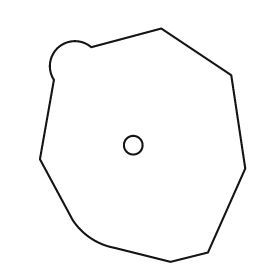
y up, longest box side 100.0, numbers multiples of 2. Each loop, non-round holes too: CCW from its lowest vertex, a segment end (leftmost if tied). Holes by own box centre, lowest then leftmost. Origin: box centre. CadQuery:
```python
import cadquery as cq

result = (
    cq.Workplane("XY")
    .moveTo(12.0, -50.0)
    .lineTo(28.0, -46.0)
    .lineTo(44.0, -10.0)
    .lineTo(38.0, 30.0)
    .lineTo(8.0, 50.0)
    .lineTo(-22.0, 42.0)
    .threePointArc((-36.0, 42.0), (-38.0, 28.0))
    .lineTo(-44.0, -6.0)
    .lineTo(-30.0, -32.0)
    .threePointArc((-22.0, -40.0), (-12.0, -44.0))
    .close()
    .moveTo(-4.0, 0.0)
    .circle(4.0)
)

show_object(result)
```